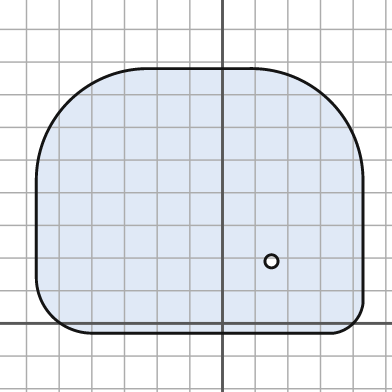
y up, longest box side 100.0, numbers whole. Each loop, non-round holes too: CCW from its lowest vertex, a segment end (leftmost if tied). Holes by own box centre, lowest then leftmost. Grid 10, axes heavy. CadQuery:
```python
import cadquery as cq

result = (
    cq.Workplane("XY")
    .moveTo(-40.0, -3.0)
    .lineTo(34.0, -3.0)
    .threePointArc((40.0, 0.0), (43.0, 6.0))
    .lineTo(43.0, 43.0)
    .threePointArc((33.0, 68.0), (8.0, 78.0))
    .lineTo(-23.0, 78.0)
    .threePointArc((-47.0, 68.0), (-57.0, 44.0))
    .lineTo(-57.0, 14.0)
    .threePointArc((-52.0, 2.0), (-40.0, -3.0))
    .close()
    .moveTo(15.0, 19.0)
    .circle(2.0)
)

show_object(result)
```